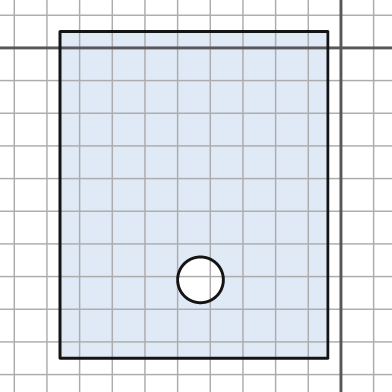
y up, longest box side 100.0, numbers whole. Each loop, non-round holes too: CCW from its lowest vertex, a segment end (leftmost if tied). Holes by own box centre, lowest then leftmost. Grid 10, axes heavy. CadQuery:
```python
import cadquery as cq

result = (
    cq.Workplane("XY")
    .moveTo(-86.0, -95.0)
    .lineTo(-4.0, -95.0)
    .lineTo(-4.0, 5.0)
    .lineTo(-86.0, 5.0)
    .close()
    .moveTo(-43.0, -71.0)
    .circle(7.0)
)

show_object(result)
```